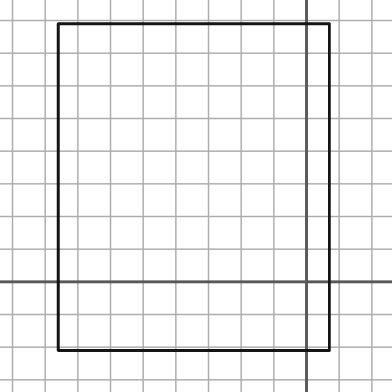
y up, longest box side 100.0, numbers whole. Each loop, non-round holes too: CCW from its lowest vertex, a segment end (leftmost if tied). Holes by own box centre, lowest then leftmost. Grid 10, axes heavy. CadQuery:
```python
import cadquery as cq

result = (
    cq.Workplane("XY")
    .moveTo(-76.0, -21.0)
    .lineTo(7.0, -21.0)
    .lineTo(7.0, 79.0)
    .lineTo(-76.0, 79.0)
    .close()
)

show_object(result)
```